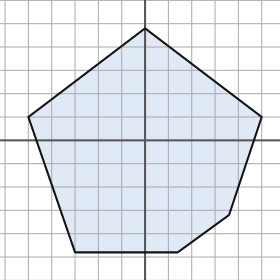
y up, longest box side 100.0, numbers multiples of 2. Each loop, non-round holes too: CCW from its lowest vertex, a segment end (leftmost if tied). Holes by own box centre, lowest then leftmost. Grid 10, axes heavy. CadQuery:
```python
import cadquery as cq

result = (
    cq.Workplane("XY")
    .moveTo(-30.0, -48.0)
    .lineTo(14.0, -48.0)
    .lineTo(36.0, -32.0)
    .lineTo(50.0, 10.0)
    .lineTo(0.0, 48.0)
    .lineTo(-50.0, 10.0)
    .close()
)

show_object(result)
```